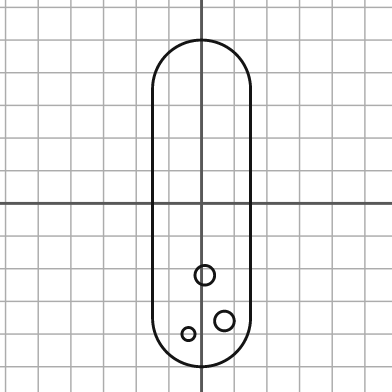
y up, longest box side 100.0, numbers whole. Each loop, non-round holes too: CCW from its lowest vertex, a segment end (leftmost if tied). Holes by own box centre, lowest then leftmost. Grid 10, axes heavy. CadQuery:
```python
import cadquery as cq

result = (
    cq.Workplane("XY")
    .moveTo(-15.0, -35.0)
    .threePointArc((0.0, -50.0), (15.0, -35.0))
    .lineTo(15.0, 35.0)
    .threePointArc((0.0, 50.0), (-15.0, 35.0))
    .close()
    .moveTo(-4.0, -40.0)
    .circle(2.0)
    .moveTo(7.0, -36.0)
    .circle(3.0)
    .moveTo(1.0, -22.0)
    .circle(3.0)
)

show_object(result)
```